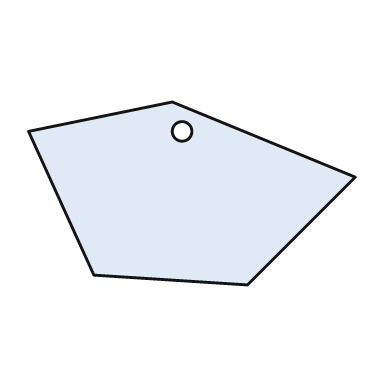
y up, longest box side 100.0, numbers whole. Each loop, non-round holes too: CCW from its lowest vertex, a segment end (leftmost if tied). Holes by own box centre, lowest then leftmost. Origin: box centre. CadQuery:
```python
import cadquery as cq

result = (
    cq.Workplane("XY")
    .moveTo(17.0, -28.0)
    .lineTo(50.0, 5.0)
    .lineTo(-6.0, 28.0)
    .lineTo(-50.0, 19.0)
    .lineTo(-30.0, -25.0)
    .close()
    .moveTo(-3.0, 19.0)
    .circle(3.0)
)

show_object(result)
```